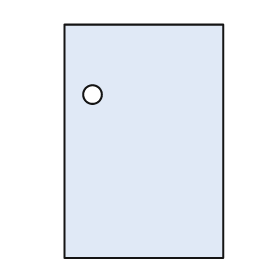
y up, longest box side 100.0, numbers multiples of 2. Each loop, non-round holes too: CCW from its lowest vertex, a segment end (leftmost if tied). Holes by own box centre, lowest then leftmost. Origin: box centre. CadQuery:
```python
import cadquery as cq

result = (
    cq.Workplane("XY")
    .moveTo(-34.0, -50.0)
    .lineTo(34.0, -50.0)
    .lineTo(34.0, 50.0)
    .lineTo(-34.0, 50.0)
    .close()
    .moveTo(-22.0, 20.0)
    .circle(4.0)
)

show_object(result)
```